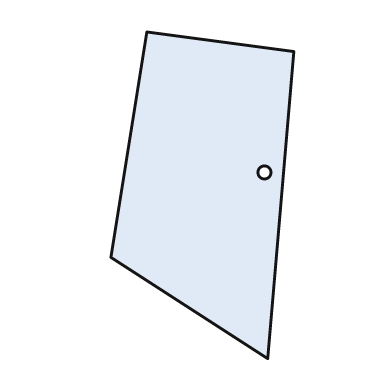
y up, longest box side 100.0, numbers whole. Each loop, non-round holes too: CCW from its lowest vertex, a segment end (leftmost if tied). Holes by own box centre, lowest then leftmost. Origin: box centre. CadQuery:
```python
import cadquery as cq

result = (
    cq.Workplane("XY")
    .moveTo(20.0, -50.0)
    .lineTo(28.0, 44.0)
    .lineTo(-17.0, 50.0)
    .lineTo(-28.0, -19.0)
    .close()
    .moveTo(19.0, 7.0)
    .circle(2.0)
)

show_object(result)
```